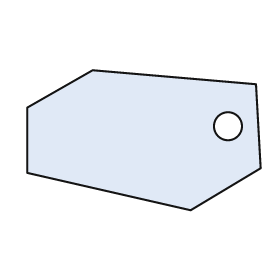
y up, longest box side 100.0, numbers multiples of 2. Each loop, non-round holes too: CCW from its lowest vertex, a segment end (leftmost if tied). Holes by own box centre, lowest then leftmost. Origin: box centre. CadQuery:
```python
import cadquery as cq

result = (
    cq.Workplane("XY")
    .moveTo(20.0, -30.0)
    .lineTo(50.0, -12.0)
    .lineTo(48.0, 24.0)
    .lineTo(-22.0, 30.0)
    .lineTo(-50.0, 14.0)
    .lineTo(-50.0, -14.0)
    .close()
    .moveTo(36.0, 6.0)
    .circle(6.0)
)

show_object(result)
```